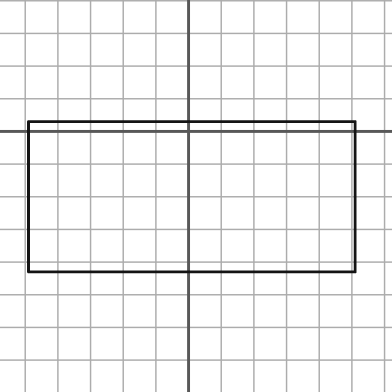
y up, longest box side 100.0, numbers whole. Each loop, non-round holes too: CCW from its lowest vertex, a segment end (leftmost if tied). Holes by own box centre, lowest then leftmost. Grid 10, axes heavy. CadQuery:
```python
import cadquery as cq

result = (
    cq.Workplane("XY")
    .moveTo(-49.0, -43.0)
    .lineTo(51.0, -43.0)
    .lineTo(51.0, 3.0)
    .lineTo(-49.0, 3.0)
    .close()
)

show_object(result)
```